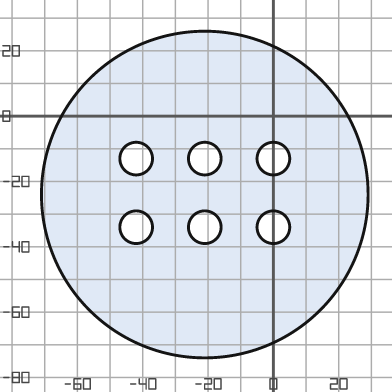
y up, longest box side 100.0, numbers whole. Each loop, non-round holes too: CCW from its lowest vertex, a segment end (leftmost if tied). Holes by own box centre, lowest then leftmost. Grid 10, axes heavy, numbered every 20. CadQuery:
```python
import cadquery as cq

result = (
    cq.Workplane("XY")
    .moveTo(-21.0, -24.0)
    .circle(50.0)
    .moveTo(-42.0, -34.0)
    .circle(5.0)
    .moveTo(-21.0, -34.0)
    .circle(5.0)
    .moveTo(0.0, -34.0)
    .circle(5.0)
    .moveTo(-42.0, -13.0)
    .circle(5.0)
    .moveTo(-21.0, -13.0)
    .circle(5.0)
    .moveTo(0.0, -13.0)
    .circle(5.0)
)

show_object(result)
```